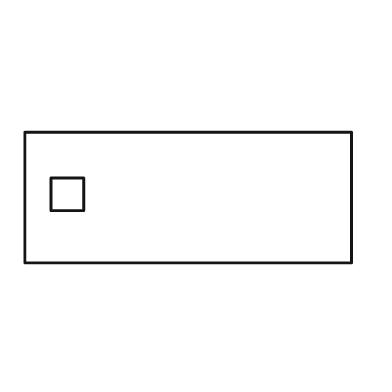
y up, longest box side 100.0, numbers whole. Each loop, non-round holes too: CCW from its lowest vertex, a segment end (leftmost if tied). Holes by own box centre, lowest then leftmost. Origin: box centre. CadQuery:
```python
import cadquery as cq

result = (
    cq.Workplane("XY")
    .moveTo(-50.0, -20.0)
    .lineTo(50.0, -20.0)
    .lineTo(50.0, 20.0)
    .lineTo(-50.0, 20.0)
    .close()
    .moveTo(-42.0, -4.0)
    .lineTo(-32.0, -4.0)
    .lineTo(-32.0, 6.0)
    .lineTo(-42.0, 6.0)
    .close()
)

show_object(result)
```